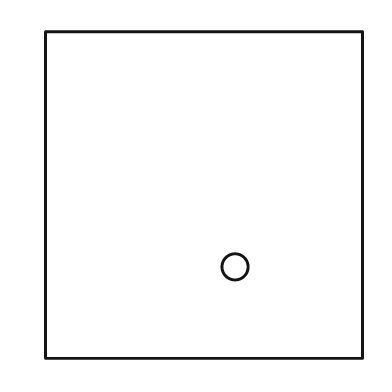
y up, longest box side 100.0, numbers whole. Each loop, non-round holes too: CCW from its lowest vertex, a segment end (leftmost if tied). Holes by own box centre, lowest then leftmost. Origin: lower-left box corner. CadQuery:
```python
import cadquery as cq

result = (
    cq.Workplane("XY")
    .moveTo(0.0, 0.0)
    .lineTo(97.0, 0.0)
    .lineTo(97.0, 100.0)
    .lineTo(0.0, 100.0)
    .close()
    .moveTo(58.0, 28.0)
    .circle(4.0)
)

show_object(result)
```